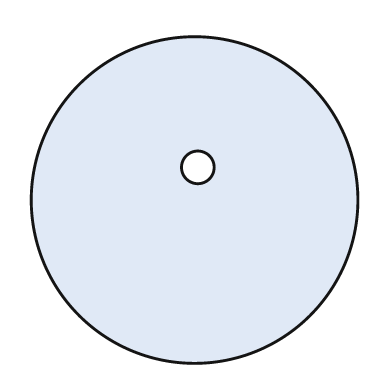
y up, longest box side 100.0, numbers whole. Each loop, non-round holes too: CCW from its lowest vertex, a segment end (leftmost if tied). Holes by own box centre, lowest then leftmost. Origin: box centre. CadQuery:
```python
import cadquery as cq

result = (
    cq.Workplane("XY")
    .moveTo(0.0, 0.0)
    .circle(50.0)
    .moveTo(1.0, 10.0)
    .circle(5.0)
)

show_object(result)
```